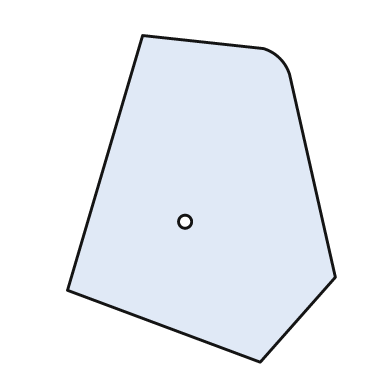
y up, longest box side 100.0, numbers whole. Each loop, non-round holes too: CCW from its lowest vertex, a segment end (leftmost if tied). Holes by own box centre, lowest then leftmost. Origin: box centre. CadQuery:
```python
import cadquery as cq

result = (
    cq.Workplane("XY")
    .moveTo(18.0, -50.0)
    .lineTo(41.0, -24.0)
    .lineTo(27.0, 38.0)
    .threePointArc((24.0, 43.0), (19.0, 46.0))
    .lineTo(-18.0, 50.0)
    .lineTo(-41.0, -28.0)
    .close()
    .moveTo(-5.0, -7.0)
    .circle(2.0)
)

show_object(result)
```